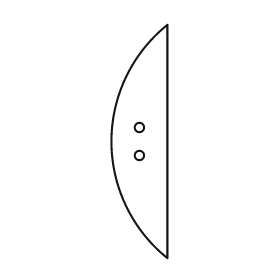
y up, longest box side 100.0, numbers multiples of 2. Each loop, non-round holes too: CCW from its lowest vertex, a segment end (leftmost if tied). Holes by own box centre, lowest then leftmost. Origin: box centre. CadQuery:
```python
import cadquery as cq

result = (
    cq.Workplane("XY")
    .moveTo(12.0, -50.0)
    .lineTo(12.0, 50.0)
    .threePointArc((-12.0, 0.0), (12.0, -50.0))
    .close()
    .moveTo(0.0, -6.0)
    .circle(2.0)
    .moveTo(0.0, 6.0)
    .circle(2.0)
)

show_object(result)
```